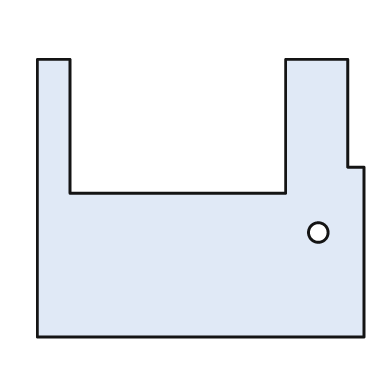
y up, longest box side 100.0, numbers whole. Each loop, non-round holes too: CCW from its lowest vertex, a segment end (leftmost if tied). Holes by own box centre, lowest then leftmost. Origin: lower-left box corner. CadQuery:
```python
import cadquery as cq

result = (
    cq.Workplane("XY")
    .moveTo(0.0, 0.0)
    .lineTo(100.0, 0.0)
    .lineTo(100.0, 52.0)
    .lineTo(95.0, 52.0)
    .lineTo(95.0, 85.0)
    .lineTo(76.0, 85.0)
    .lineTo(76.0, 44.0)
    .lineTo(10.0, 44.0)
    .lineTo(10.0, 85.0)
    .lineTo(0.0, 85.0)
    .close()
    .moveTo(86.0, 32.0)
    .circle(3.0)
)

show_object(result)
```